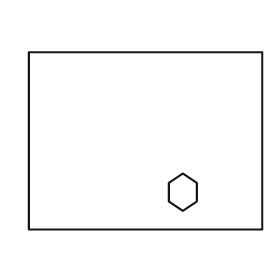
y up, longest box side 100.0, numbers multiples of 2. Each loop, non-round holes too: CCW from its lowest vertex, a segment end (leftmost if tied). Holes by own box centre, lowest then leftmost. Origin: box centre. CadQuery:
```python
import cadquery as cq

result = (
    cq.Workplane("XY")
    .moveTo(-50.0, -38.0)
    .lineTo(50.0, -38.0)
    .lineTo(50.0, 38.0)
    .lineTo(-50.0, 38.0)
    .close()
    .moveTo(16.0, -30.0)
    .lineTo(22.0, -26.0)
    .lineTo(22.0, -18.0)
    .lineTo(16.0, -14.0)
    .lineTo(10.0, -18.0)
    .lineTo(10.0, -26.0)
    .close()
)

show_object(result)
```